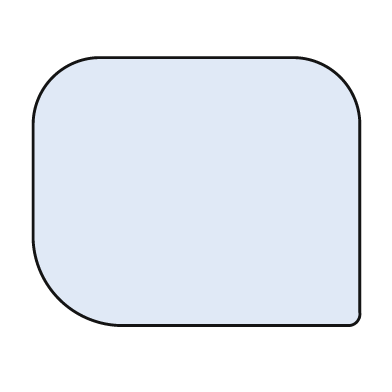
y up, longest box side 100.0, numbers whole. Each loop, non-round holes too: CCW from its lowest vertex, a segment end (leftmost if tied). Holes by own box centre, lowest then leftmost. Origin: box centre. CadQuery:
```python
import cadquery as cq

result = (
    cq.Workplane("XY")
    .moveTo(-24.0, -41.0)
    .lineTo(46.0, -41.0)
    .threePointArc((49.0, -40.0), (50.0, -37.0))
    .lineTo(50.0, 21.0)
    .threePointArc((44.0, 35.0), (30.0, 41.0))
    .lineTo(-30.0, 41.0)
    .threePointArc((-44.0, 35.0), (-50.0, 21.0))
    .lineTo(-50.0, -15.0)
    .threePointArc((-42.0, -33.0), (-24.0, -41.0))
    .close()
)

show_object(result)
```